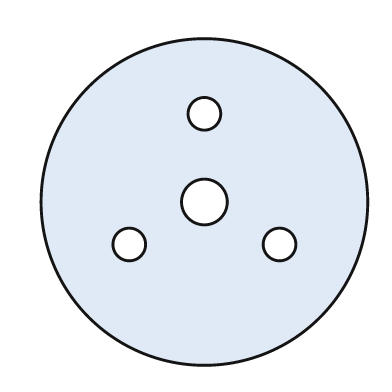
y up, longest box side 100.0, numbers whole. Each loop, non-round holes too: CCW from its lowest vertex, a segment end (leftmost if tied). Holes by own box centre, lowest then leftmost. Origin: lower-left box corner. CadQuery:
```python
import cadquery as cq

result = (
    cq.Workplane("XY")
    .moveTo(50.0, 50.0)
    .circle(50.0)
    .moveTo(27.0, 37.0)
    .circle(5.0)
    .moveTo(73.0, 37.0)
    .circle(5.0)
    .moveTo(50.0, 50.0)
    .circle(7.0)
    .moveTo(50.0, 77.0)
    .circle(5.0)
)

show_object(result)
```